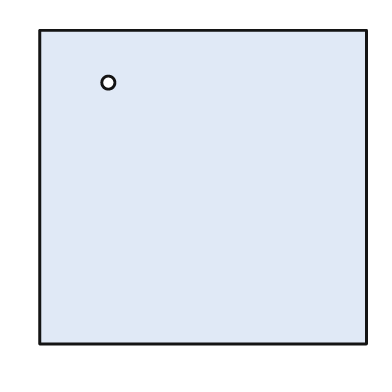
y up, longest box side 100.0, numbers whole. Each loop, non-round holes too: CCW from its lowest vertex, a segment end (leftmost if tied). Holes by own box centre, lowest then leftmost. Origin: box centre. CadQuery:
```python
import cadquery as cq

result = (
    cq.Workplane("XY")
    .moveTo(-50.0, -48.0)
    .lineTo(50.0, -48.0)
    .lineTo(50.0, 48.0)
    .lineTo(-50.0, 48.0)
    .close()
    .moveTo(-29.0, 32.0)
    .circle(2.0)
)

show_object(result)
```